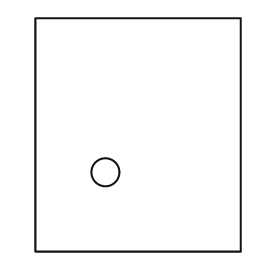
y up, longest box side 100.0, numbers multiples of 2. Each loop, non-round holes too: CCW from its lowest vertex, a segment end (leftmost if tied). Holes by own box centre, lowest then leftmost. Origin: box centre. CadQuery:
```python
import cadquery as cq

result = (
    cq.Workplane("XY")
    .moveTo(-44.0, -50.0)
    .lineTo(44.0, -50.0)
    .lineTo(44.0, 50.0)
    .lineTo(-44.0, 50.0)
    .close()
    .moveTo(-14.0, -16.0)
    .circle(6.0)
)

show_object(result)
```